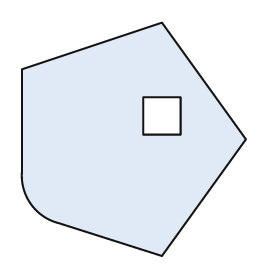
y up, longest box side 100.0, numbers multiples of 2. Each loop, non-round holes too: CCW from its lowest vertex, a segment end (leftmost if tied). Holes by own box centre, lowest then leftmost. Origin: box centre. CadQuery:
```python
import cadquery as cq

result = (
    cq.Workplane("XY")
    .moveTo(12.0, -50.0)
    .lineTo(48.0, 0.0)
    .lineTo(12.0, 50.0)
    .lineTo(-48.0, 30.0)
    .lineTo(-48.0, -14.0)
    .threePointArc((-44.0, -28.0), (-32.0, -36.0))
    .close()
    .moveTo(4.0, 2.0)
    .lineTo(20.0, 2.0)
    .lineTo(20.0, 18.0)
    .lineTo(4.0, 18.0)
    .close()
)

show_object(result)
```